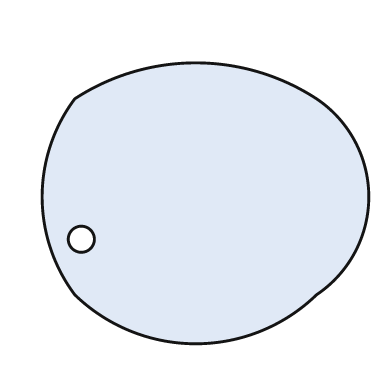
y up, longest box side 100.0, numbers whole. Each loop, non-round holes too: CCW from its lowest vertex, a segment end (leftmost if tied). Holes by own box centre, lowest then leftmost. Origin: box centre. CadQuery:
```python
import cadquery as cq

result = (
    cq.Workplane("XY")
    .moveTo(-40.0, -28.0)
    .threePointArc((-3.0, -43.0), (34.0, -28.0))
    .threePointArc((50.0, 2.0), (34.0, 32.0))
    .threePointArc((-3.0, 43.0), (-40.0, 32.0))
    .threePointArc((-50.0, 2.0), (-40.0, -28.0))
    .close()
    .moveTo(-38.0, -11.0)
    .circle(4.0)
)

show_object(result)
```